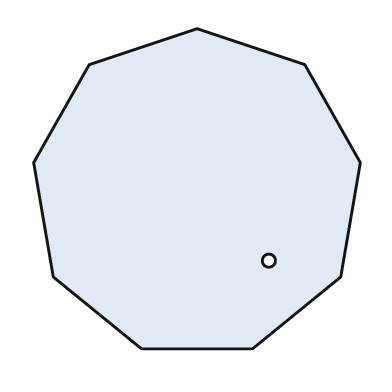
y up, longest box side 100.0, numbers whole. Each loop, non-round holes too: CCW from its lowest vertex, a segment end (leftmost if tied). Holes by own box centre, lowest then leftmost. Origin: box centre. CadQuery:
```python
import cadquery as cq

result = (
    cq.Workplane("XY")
    .moveTo(-17.0, -49.0)
    .lineTo(17.0, -49.0)
    .lineTo(44.0, -27.0)
    .lineTo(50.0, 8.0)
    .lineTo(33.0, 38.0)
    .lineTo(0.0, 49.0)
    .lineTo(-33.0, 38.0)
    .lineTo(-50.0, 8.0)
    .lineTo(-44.0, -27.0)
    .close()
    .moveTo(22.0, -22.0)
    .circle(2.0)
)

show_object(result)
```